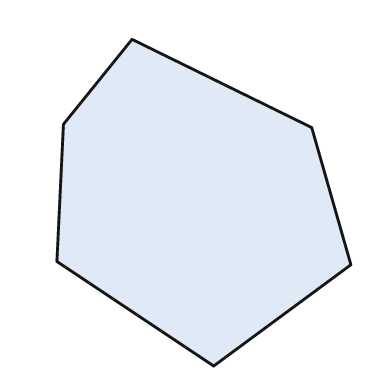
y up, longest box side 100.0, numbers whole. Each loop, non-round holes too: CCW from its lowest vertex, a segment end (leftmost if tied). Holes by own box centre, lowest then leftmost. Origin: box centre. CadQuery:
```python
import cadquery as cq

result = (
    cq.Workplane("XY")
    .moveTo(3.0, -50.0)
    .lineTo(45.0, -19.0)
    .lineTo(33.0, 23.0)
    .lineTo(-22.0, 50.0)
    .lineTo(-43.0, 24.0)
    .lineTo(-45.0, -18.0)
    .close()
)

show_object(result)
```